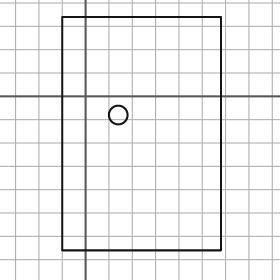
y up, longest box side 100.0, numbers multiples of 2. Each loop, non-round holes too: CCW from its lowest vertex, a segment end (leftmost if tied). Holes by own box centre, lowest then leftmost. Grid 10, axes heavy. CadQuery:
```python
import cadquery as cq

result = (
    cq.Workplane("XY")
    .moveTo(-10.0, -66.0)
    .lineTo(58.0, -66.0)
    .lineTo(58.0, 34.0)
    .lineTo(-10.0, 34.0)
    .close()
    .moveTo(14.0, -8.0)
    .circle(4.0)
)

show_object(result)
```